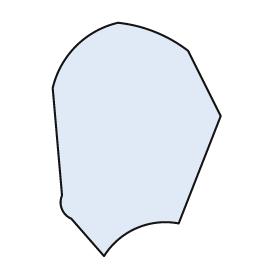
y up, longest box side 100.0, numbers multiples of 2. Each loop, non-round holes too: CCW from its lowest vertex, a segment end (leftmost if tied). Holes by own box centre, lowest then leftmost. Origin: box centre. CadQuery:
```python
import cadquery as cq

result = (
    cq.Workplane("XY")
    .moveTo(-14.0, -50.0)
    .threePointArc((0.0, -38.0), (18.0, -36.0))
    .lineTo(36.0, 10.0)
    .lineTo(22.0, 38.0)
    .threePointArc((8.0, 46.0), (-8.0, 50.0))
    .threePointArc((-26.0, 40.0), (-36.0, 22.0))
    .lineTo(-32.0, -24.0)
    .threePointArc((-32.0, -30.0), (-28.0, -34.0))
    .close()
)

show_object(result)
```